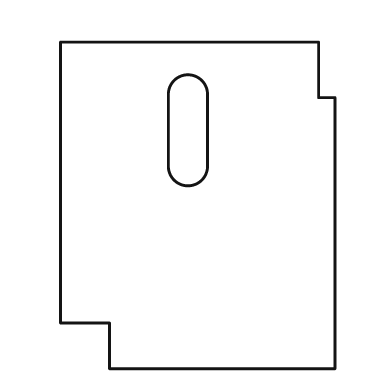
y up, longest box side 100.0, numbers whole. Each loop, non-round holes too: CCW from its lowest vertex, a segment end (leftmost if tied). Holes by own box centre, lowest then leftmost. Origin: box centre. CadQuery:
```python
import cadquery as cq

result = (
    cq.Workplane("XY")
    .moveTo(-27.0, -50.0)
    .lineTo(42.0, -50.0)
    .lineTo(42.0, 33.0)
    .lineTo(37.0, 33.0)
    .lineTo(37.0, 50.0)
    .lineTo(-42.0, 50.0)
    .lineTo(-42.0, -36.0)
    .lineTo(-27.0, -36.0)
    .close()
    .moveTo(-9.0, 12.0)
    .threePointArc((-3.0, 6.0), (3.0, 12.0))
    .lineTo(3.0, 34.0)
    .threePointArc((-3.0, 40.0), (-9.0, 34.0))
    .close()
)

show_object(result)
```